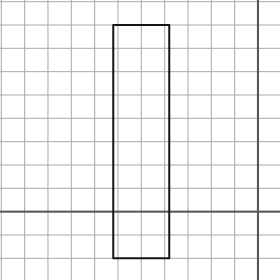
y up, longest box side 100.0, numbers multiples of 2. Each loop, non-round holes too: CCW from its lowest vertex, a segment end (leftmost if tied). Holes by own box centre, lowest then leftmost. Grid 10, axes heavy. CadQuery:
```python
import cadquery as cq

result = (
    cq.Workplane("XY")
    .moveTo(-62.0, -20.0)
    .lineTo(-38.0, -20.0)
    .lineTo(-38.0, 80.0)
    .lineTo(-62.0, 80.0)
    .close()
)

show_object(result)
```